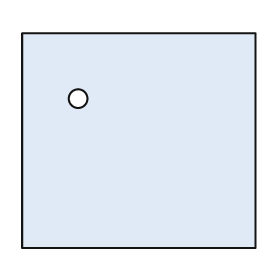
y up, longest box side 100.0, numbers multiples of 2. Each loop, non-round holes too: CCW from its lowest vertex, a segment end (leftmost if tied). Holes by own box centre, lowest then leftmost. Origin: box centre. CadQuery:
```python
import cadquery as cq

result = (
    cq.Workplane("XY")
    .moveTo(-50.0, -46.0)
    .lineTo(50.0, -46.0)
    .lineTo(50.0, 46.0)
    .lineTo(-50.0, 46.0)
    .close()
    .moveTo(-26.0, 18.0)
    .circle(4.0)
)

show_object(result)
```